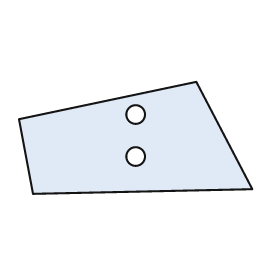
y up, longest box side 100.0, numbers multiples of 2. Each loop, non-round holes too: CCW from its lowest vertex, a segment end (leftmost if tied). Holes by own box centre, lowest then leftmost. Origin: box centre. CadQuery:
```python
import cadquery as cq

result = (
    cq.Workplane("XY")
    .moveTo(-44.0, -24.0)
    .lineTo(50.0, -22.0)
    .lineTo(26.0, 24.0)
    .lineTo(-50.0, 8.0)
    .close()
    .moveTo(0.0, -8.0)
    .circle(4.0)
    .moveTo(0.0, 10.0)
    .circle(4.0)
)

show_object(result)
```